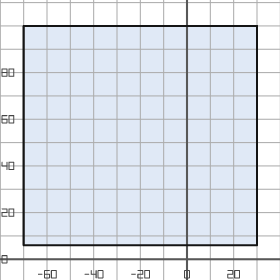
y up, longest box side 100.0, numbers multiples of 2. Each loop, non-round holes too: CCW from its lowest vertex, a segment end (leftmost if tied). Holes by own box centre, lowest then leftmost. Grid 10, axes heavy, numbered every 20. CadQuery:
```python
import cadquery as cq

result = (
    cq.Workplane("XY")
    .moveTo(-70.0, 6.0)
    .lineTo(30.0, 6.0)
    .lineTo(30.0, 100.0)
    .lineTo(-70.0, 100.0)
    .close()
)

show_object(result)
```